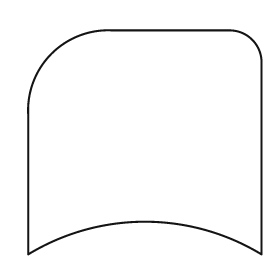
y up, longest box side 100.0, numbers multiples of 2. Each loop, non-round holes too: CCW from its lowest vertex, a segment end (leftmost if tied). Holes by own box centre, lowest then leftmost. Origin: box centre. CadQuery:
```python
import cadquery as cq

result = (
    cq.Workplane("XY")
    .moveTo(-50.0, -48.0)
    .threePointArc((0.0, -34.0), (50.0, -48.0))
    .lineTo(50.0, 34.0)
    .threePointArc((46.0, 44.0), (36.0, 48.0))
    .lineTo(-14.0, 48.0)
    .threePointArc((-40.0, 38.0), (-50.0, 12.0))
    .close()
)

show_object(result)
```